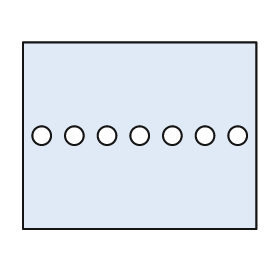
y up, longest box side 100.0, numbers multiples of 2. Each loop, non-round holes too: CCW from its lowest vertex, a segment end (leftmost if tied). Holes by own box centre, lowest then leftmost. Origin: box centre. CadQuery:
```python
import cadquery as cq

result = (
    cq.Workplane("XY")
    .moveTo(-50.0, -40.0)
    .lineTo(50.0, -40.0)
    .lineTo(50.0, 40.0)
    .lineTo(-50.0, 40.0)
    .close()
    .moveTo(-42.0, 0.0)
    .circle(4.0)
    .moveTo(-28.0, 0.0)
    .circle(4.0)
    .moveTo(-14.0, 0.0)
    .circle(4.0)
    .moveTo(0.0, 0.0)
    .circle(4.0)
    .moveTo(14.0, 0.0)
    .circle(4.0)
    .moveTo(28.0, 0.0)
    .circle(4.0)
    .moveTo(42.0, 0.0)
    .circle(4.0)
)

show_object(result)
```